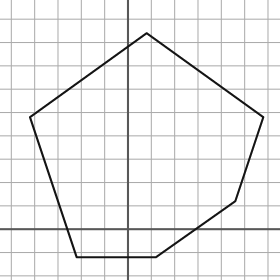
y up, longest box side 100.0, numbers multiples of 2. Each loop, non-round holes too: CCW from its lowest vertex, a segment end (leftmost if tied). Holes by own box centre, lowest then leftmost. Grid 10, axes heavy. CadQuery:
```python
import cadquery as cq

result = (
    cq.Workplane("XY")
    .moveTo(-22.0, -12.0)
    .lineTo(12.0, -12.0)
    .lineTo(46.0, 12.0)
    .lineTo(58.0, 48.0)
    .lineTo(8.0, 84.0)
    .lineTo(-42.0, 48.0)
    .close()
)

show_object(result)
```